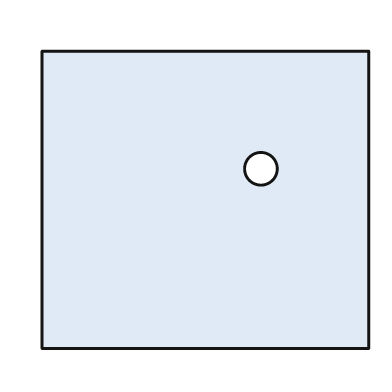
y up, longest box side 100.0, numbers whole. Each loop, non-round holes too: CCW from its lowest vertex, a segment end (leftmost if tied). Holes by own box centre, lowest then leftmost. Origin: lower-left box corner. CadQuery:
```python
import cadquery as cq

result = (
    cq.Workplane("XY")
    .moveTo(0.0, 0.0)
    .lineTo(100.0, 0.0)
    .lineTo(100.0, 91.0)
    .lineTo(0.0, 91.0)
    .close()
    .moveTo(67.0, 55.0)
    .circle(5.0)
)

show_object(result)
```